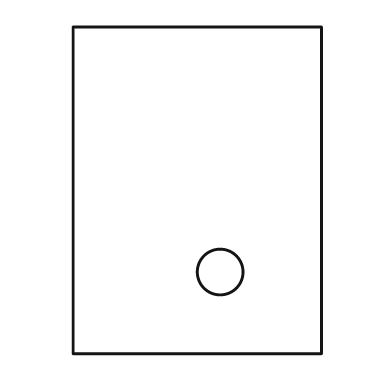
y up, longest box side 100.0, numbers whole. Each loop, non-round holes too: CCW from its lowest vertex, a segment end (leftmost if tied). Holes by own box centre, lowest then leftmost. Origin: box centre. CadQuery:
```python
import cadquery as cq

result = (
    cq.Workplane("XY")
    .moveTo(-38.0, -50.0)
    .lineTo(38.0, -50.0)
    .lineTo(38.0, 50.0)
    .lineTo(-38.0, 50.0)
    .close()
    .moveTo(7.0, -25.0)
    .circle(7.0)
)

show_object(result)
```